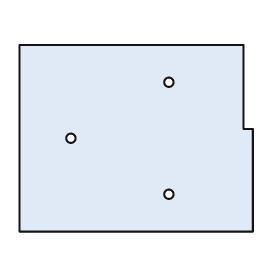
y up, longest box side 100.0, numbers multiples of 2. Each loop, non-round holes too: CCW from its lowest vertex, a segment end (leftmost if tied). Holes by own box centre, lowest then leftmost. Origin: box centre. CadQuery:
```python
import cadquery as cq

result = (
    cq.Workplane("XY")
    .moveTo(-50.0, -40.0)
    .lineTo(50.0, -40.0)
    .lineTo(50.0, 4.0)
    .lineTo(46.0, 4.0)
    .lineTo(46.0, 40.0)
    .lineTo(-50.0, 40.0)
    .close()
    .moveTo(14.0, -24.0)
    .circle(2.0)
    .moveTo(-28.0, 0.0)
    .circle(2.0)
    .moveTo(14.0, 24.0)
    .circle(2.0)
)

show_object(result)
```